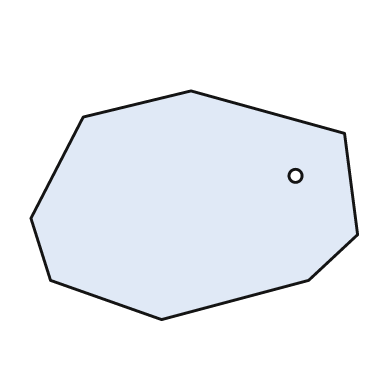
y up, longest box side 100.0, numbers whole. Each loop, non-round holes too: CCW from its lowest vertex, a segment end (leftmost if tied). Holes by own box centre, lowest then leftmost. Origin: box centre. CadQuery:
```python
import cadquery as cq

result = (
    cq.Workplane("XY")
    .moveTo(-10.0, -35.0)
    .lineTo(35.0, -23.0)
    .lineTo(50.0, -9.0)
    .lineTo(46.0, 22.0)
    .lineTo(-1.0, 35.0)
    .lineTo(-34.0, 27.0)
    .lineTo(-50.0, -4.0)
    .lineTo(-44.0, -23.0)
    .close()
    .moveTo(31.0, 9.0)
    .circle(2.0)
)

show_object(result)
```